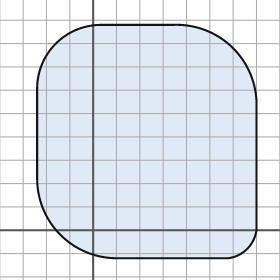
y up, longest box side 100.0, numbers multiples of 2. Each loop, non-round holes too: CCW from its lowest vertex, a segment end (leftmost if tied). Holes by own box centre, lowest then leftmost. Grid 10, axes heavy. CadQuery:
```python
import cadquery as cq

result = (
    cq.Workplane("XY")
    .moveTo(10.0, -12.0)
    .lineTo(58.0, -12.0)
    .threePointArc((66.0, -8.0), (70.0, 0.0))
    .lineTo(70.0, 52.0)
    .threePointArc((60.0, 78.0), (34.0, 88.0))
    .lineTo(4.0, 88.0)
    .threePointArc((-16.0, 80.0), (-24.0, 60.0))
    .lineTo(-24.0, 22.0)
    .threePointArc((-14.0, -2.0), (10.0, -12.0))
    .close()
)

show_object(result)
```